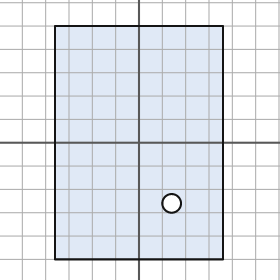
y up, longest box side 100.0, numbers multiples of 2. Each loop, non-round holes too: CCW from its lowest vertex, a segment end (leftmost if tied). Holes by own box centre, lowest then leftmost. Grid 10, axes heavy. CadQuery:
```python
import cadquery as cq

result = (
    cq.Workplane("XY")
    .moveTo(-36.0, -50.0)
    .lineTo(36.0, -50.0)
    .lineTo(36.0, 50.0)
    .lineTo(-36.0, 50.0)
    .close()
    .moveTo(14.0, -26.0)
    .circle(4.0)
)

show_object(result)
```